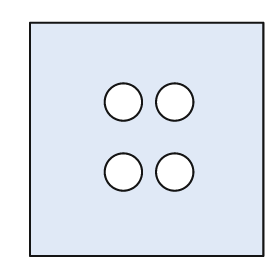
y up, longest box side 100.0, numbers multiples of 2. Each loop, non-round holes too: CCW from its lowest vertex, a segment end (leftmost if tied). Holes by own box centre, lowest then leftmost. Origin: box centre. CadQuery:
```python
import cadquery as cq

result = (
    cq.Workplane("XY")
    .moveTo(-50.0, -50.0)
    .lineTo(50.0, -50.0)
    .lineTo(50.0, 50.0)
    .lineTo(-50.0, 50.0)
    .close()
    .moveTo(-10.0, -14.0)
    .circle(8.0)
    .moveTo(12.0, -14.0)
    .circle(8.0)
    .moveTo(-10.0, 16.0)
    .circle(8.0)
    .moveTo(12.0, 16.0)
    .circle(8.0)
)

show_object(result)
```